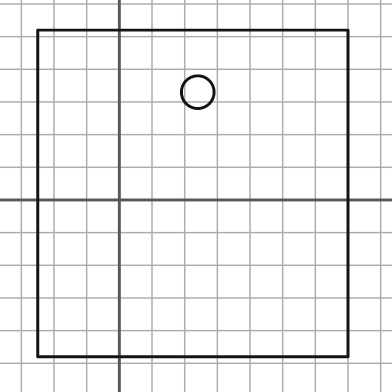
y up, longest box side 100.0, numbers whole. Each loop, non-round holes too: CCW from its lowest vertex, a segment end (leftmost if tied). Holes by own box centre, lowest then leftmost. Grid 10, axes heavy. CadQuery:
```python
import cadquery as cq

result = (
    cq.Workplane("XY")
    .moveTo(-25.0, -48.0)
    .lineTo(70.0, -48.0)
    .lineTo(70.0, 52.0)
    .lineTo(-25.0, 52.0)
    .close()
    .moveTo(24.0, 33.0)
    .circle(5.0)
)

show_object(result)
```